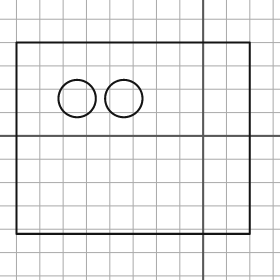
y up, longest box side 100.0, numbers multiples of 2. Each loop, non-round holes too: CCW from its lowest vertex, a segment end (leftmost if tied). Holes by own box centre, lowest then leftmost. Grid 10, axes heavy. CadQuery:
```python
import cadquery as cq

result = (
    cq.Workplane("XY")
    .moveTo(-80.0, -42.0)
    .lineTo(20.0, -42.0)
    .lineTo(20.0, 40.0)
    .lineTo(-80.0, 40.0)
    .close()
    .moveTo(-54.0, 16.0)
    .circle(8.0)
    .moveTo(-34.0, 16.0)
    .circle(8.0)
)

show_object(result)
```